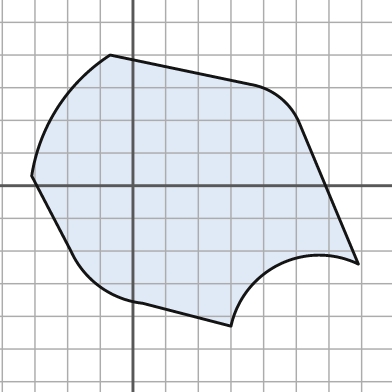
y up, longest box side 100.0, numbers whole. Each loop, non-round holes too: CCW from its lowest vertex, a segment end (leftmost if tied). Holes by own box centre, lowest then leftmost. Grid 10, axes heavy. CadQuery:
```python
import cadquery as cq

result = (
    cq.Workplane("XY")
    .moveTo(30.0, -43.0)
    .threePointArc((45.0, -24.0), (69.0, -24.0))
    .lineTo(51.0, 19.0)
    .threePointArc((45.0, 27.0), (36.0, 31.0))
    .lineTo(-7.0, 40.0)
    .threePointArc((-23.0, 24.0), (-31.0, 3.0))
    .lineTo(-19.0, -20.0)
    .threePointArc((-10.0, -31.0), (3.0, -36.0))
    .close()
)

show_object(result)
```